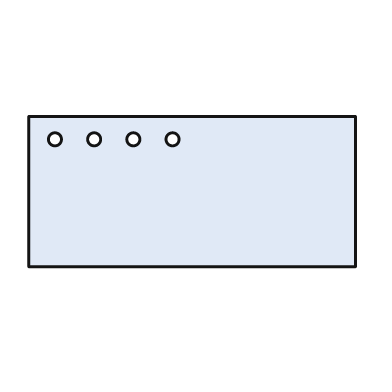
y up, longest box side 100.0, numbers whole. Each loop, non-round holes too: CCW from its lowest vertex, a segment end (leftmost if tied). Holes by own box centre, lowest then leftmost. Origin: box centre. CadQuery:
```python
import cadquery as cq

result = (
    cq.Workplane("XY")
    .moveTo(-50.0, -23.0)
    .lineTo(50.0, -23.0)
    .lineTo(50.0, 23.0)
    .lineTo(-50.0, 23.0)
    .close()
    .moveTo(-42.0, 16.0)
    .circle(2.0)
    .moveTo(-30.0, 16.0)
    .circle(2.0)
    .moveTo(-18.0, 16.0)
    .circle(2.0)
    .moveTo(-6.0, 16.0)
    .circle(2.0)
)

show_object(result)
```